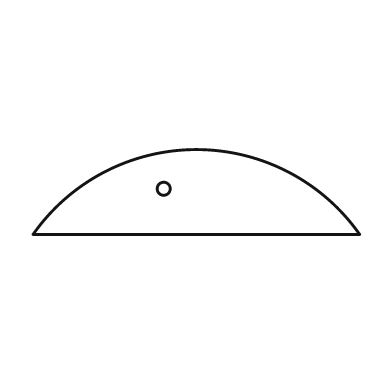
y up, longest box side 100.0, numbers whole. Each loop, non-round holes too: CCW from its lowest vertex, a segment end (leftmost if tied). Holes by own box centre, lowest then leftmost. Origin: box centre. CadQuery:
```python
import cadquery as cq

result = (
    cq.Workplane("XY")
    .moveTo(-50.0, -13.0)
    .lineTo(50.0, -13.0)
    .threePointArc((0.0, 13.0), (-50.0, -13.0))
    .close()
    .moveTo(-10.0, 1.0)
    .circle(2.0)
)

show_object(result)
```